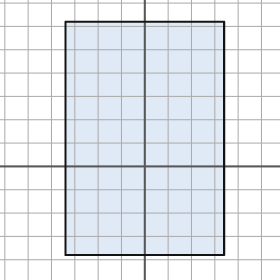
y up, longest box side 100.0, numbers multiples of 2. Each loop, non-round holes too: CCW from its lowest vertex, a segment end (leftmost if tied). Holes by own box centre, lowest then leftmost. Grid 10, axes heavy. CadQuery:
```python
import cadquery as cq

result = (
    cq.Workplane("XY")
    .moveTo(-34.0, -38.0)
    .lineTo(34.0, -38.0)
    .lineTo(34.0, 62.0)
    .lineTo(-34.0, 62.0)
    .close()
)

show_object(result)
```